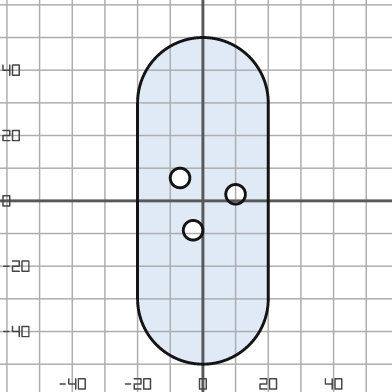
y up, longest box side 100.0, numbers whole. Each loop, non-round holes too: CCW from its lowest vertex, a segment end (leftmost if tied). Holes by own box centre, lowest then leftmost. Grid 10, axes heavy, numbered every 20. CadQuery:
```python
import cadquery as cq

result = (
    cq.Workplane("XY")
    .moveTo(-20.0, -30.0)
    .threePointArc((0.0, -50.0), (20.0, -30.0))
    .lineTo(20.0, 30.0)
    .threePointArc((0.0, 50.0), (-20.0, 30.0))
    .close()
    .moveTo(-3.0, -9.0)
    .circle(3.0)
    .moveTo(10.0, 2.0)
    .circle(3.0)
    .moveTo(-7.0, 7.0)
    .circle(3.0)
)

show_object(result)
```